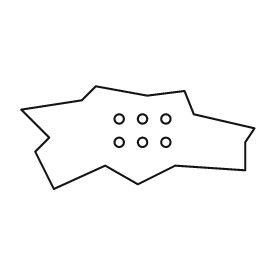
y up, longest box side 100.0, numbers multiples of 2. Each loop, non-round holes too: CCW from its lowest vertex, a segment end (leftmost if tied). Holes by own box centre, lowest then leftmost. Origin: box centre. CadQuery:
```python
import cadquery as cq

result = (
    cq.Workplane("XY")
    .moveTo(-36.0, -22.0)
    .lineTo(-14.0, -12.0)
    .lineTo(0.0, -20.0)
    .lineTo(16.0, -12.0)
    .lineTo(46.0, -14.0)
    .lineTo(46.0, -2.0)
    .lineTo(50.0, 4.0)
    .lineTo(24.0, 10.0)
    .lineTo(20.0, 20.0)
    .lineTo(4.0, 18.0)
    .lineTo(-18.0, 22.0)
    .lineTo(-24.0, 16.0)
    .lineTo(-50.0, 12.0)
    .lineTo(-38.0, 0.0)
    .lineTo(-44.0, -6.0)
    .close()
    .moveTo(-8.0, -2.0)
    .circle(2.0)
    .moveTo(2.0, -2.0)
    .circle(2.0)
    .moveTo(12.0, -2.0)
    .circle(2.0)
    .moveTo(-8.0, 8.0)
    .circle(2.0)
    .moveTo(2.0, 8.0)
    .circle(2.0)
    .moveTo(12.0, 8.0)
    .circle(2.0)
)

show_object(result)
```